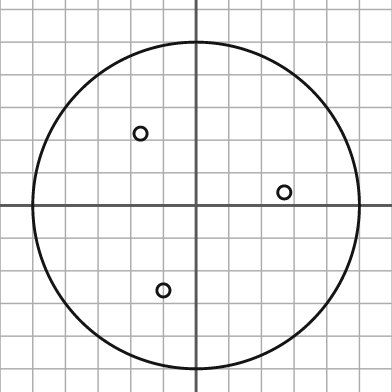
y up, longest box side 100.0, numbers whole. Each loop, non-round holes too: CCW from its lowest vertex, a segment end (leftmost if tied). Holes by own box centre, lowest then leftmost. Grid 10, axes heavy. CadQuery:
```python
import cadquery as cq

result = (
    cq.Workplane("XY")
    .moveTo(0.0, 0.0)
    .circle(50.0)
    .moveTo(-10.0, -26.0)
    .circle(2.0)
    .moveTo(27.0, 4.0)
    .circle(2.0)
    .moveTo(-17.0, 22.0)
    .circle(2.0)
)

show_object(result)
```